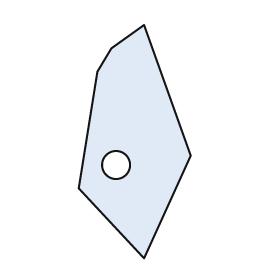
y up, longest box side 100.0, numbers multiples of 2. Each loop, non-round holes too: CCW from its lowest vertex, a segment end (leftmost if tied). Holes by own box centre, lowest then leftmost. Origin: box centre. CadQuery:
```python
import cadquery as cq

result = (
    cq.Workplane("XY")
    .moveTo(4.0, -50.0)
    .lineTo(24.0, -6.0)
    .lineTo(4.0, 50.0)
    .lineTo(-10.0, 40.0)
    .lineTo(-16.0, 30.0)
    .lineTo(-24.0, -20.0)
    .close()
    .moveTo(-8.0, -10.0)
    .circle(6.0)
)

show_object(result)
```